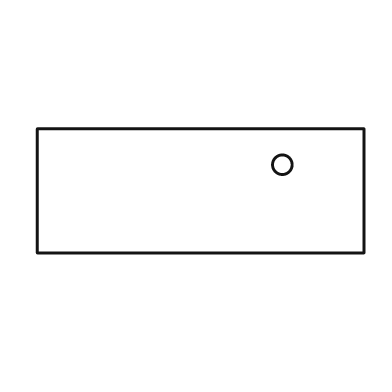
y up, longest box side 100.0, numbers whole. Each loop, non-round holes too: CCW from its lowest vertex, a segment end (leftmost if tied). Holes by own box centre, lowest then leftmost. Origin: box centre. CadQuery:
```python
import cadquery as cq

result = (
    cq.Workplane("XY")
    .moveTo(-50.0, -19.0)
    .lineTo(50.0, -19.0)
    .lineTo(50.0, 19.0)
    .lineTo(-50.0, 19.0)
    .close()
    .moveTo(25.0, 8.0)
    .circle(3.0)
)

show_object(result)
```